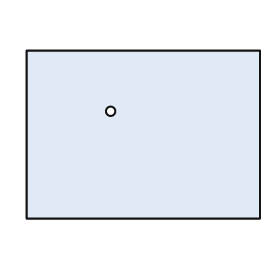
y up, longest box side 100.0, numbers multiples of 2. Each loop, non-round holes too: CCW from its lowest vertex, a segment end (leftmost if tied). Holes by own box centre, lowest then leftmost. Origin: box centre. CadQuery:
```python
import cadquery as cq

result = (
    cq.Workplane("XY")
    .moveTo(-50.0, -36.0)
    .lineTo(50.0, -36.0)
    .lineTo(50.0, 36.0)
    .lineTo(-50.0, 36.0)
    .close()
    .moveTo(-14.0, 10.0)
    .circle(2.0)
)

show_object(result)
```